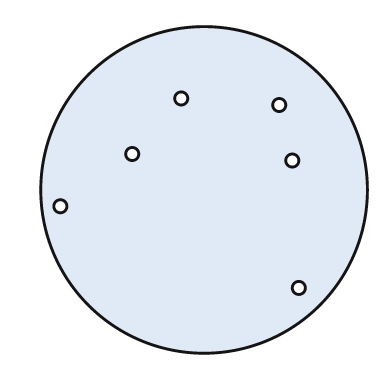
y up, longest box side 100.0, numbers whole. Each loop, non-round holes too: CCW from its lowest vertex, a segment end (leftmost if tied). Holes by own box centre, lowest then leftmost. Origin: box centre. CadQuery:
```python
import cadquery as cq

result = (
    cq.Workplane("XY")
    .moveTo(0.0, 0.0)
    .circle(50.0)
    .moveTo(29.0, -30.0)
    .circle(2.0)
    .moveTo(-44.0, -5.0)
    .circle(2.0)
    .moveTo(27.0, 9.0)
    .circle(2.0)
    .moveTo(-22.0, 11.0)
    .circle(2.0)
    .moveTo(23.0, 26.0)
    .circle(2.0)
    .moveTo(-7.0, 28.0)
    .circle(2.0)
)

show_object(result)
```